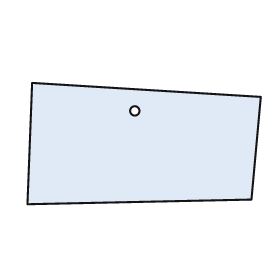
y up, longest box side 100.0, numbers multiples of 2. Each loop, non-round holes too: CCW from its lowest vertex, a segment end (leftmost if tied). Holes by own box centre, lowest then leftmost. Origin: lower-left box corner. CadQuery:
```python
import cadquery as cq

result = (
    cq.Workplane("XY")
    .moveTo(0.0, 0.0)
    .lineTo(96.0, 2.0)
    .lineTo(100.0, 46.0)
    .lineTo(2.0, 52.0)
    .close()
    .moveTo(46.0, 40.0)
    .circle(2.0)
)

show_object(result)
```